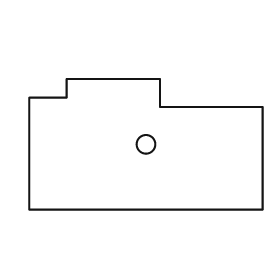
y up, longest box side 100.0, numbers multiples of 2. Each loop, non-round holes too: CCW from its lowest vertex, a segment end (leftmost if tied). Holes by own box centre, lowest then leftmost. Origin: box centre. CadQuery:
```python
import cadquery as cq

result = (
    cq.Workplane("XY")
    .moveTo(-50.0, -28.0)
    .lineTo(50.0, -28.0)
    .lineTo(50.0, 16.0)
    .lineTo(6.0, 16.0)
    .lineTo(6.0, 28.0)
    .lineTo(-34.0, 28.0)
    .lineTo(-34.0, 20.0)
    .lineTo(-50.0, 20.0)
    .close()
    .moveTo(0.0, 0.0)
    .circle(4.0)
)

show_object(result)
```